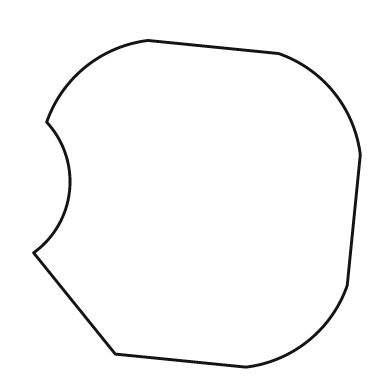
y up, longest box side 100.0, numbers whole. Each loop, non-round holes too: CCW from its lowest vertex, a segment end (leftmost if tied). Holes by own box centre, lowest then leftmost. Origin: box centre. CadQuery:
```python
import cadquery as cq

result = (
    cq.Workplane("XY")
    .moveTo(15.0, -50.0)
    .threePointArc((34.0, -42.0), (46.0, -25.0))
    .lineTo(50.0, 15.0)
    .threePointArc((42.0, 34.0), (25.0, 46.0))
    .lineTo(-15.0, 50.0)
    .threePointArc((-34.0, 42.0), (-46.0, 25.0))
    .threePointArc((-39.0, 4.0), (-50.0, -15.0))
    .lineTo(-25.0, -46.0)
    .close()
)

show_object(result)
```